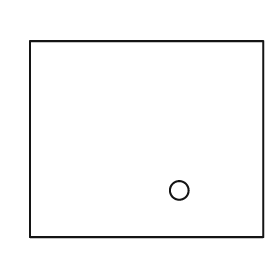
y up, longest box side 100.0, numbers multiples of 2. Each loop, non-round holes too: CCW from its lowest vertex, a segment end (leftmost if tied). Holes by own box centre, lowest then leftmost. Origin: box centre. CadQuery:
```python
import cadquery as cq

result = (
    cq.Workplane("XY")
    .moveTo(-50.0, -42.0)
    .lineTo(50.0, -42.0)
    .lineTo(50.0, 42.0)
    .lineTo(-50.0, 42.0)
    .close()
    .moveTo(14.0, -22.0)
    .circle(4.0)
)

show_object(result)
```